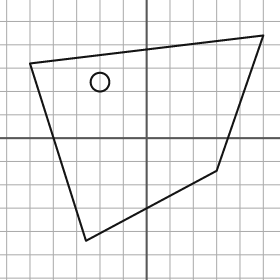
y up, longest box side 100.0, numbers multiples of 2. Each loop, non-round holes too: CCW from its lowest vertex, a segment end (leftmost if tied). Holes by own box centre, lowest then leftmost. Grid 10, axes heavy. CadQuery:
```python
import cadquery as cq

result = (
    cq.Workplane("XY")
    .moveTo(-26.0, -44.0)
    .lineTo(30.0, -14.0)
    .lineTo(50.0, 44.0)
    .lineTo(-50.0, 32.0)
    .close()
    .moveTo(-20.0, 24.0)
    .circle(4.0)
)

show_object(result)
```